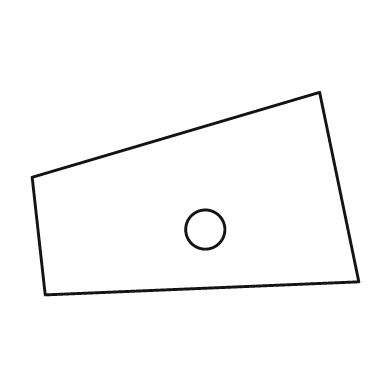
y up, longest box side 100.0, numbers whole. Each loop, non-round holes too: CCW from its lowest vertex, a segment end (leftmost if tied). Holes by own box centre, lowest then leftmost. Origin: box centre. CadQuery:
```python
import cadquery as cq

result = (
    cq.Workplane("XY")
    .moveTo(-46.0, -31.0)
    .lineTo(50.0, -27.0)
    .lineTo(38.0, 31.0)
    .lineTo(-50.0, 5.0)
    .close()
    .moveTo(3.0, -11.0)
    .circle(6.0)
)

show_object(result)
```